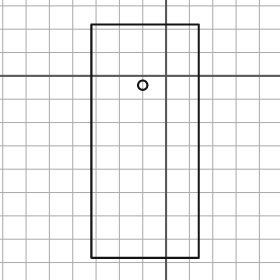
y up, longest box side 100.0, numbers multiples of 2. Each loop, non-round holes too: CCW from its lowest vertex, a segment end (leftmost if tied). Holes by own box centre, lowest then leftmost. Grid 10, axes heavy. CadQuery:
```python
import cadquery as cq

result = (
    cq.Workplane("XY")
    .moveTo(-32.0, -78.0)
    .lineTo(14.0, -78.0)
    .lineTo(14.0, 22.0)
    .lineTo(-32.0, 22.0)
    .close()
    .moveTo(-10.0, -4.0)
    .circle(2.0)
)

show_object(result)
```